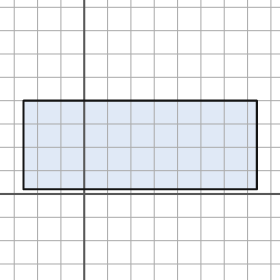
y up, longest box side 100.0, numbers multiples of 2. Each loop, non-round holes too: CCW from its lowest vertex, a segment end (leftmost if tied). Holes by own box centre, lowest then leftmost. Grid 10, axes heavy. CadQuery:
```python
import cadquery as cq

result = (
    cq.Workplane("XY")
    .moveTo(-26.0, 2.0)
    .lineTo(74.0, 2.0)
    .lineTo(74.0, 40.0)
    .lineTo(-26.0, 40.0)
    .close()
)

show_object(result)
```